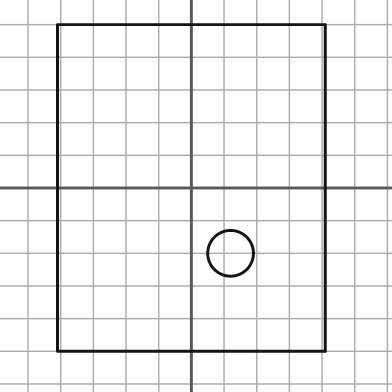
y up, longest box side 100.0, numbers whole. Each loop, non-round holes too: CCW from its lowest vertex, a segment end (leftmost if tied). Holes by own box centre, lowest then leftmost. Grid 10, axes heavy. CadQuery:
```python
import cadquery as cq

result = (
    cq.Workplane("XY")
    .moveTo(-41.0, -50.0)
    .lineTo(41.0, -50.0)
    .lineTo(41.0, 50.0)
    .lineTo(-41.0, 50.0)
    .close()
    .moveTo(12.0, -20.0)
    .circle(7.0)
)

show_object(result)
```